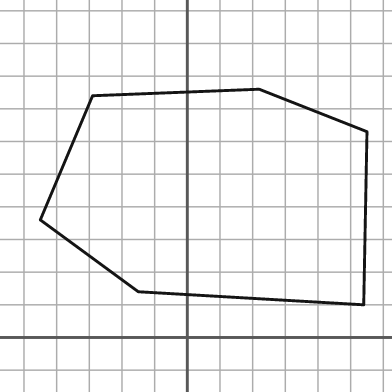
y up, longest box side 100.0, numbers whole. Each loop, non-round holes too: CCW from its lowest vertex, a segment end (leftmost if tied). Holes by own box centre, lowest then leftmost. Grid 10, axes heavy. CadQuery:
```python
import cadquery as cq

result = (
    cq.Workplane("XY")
    .moveTo(54.0, 10.0)
    .lineTo(55.0, 63.0)
    .lineTo(22.0, 76.0)
    .lineTo(-29.0, 74.0)
    .lineTo(-45.0, 36.0)
    .lineTo(-15.0, 14.0)
    .close()
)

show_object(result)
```